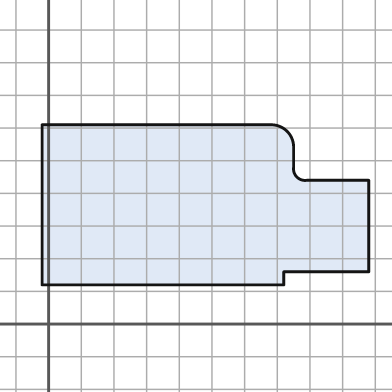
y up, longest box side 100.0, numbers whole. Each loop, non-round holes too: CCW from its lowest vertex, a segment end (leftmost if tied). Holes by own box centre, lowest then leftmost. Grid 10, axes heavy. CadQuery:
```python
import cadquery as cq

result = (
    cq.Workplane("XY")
    .moveTo(-2.0, 12.0)
    .lineTo(72.0, 12.0)
    .lineTo(72.0, 16.0)
    .lineTo(98.0, 16.0)
    .lineTo(98.0, 44.0)
    .lineTo(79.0, 44.0)
    .threePointArc((76.0, 45.0), (75.0, 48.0))
    .lineTo(75.0, 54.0)
    .threePointArc((73.0, 59.0), (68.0, 61.0))
    .lineTo(-2.0, 61.0)
    .close()
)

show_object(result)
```